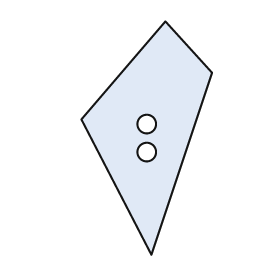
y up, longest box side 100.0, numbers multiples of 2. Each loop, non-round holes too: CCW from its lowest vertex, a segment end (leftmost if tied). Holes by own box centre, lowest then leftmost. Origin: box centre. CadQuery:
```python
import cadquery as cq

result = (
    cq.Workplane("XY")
    .moveTo(2.0, -50.0)
    .lineTo(28.0, 28.0)
    .lineTo(8.0, 50.0)
    .lineTo(-28.0, 8.0)
    .close()
    .moveTo(0.0, -6.0)
    .circle(4.0)
    .moveTo(0.0, 6.0)
    .circle(4.0)
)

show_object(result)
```